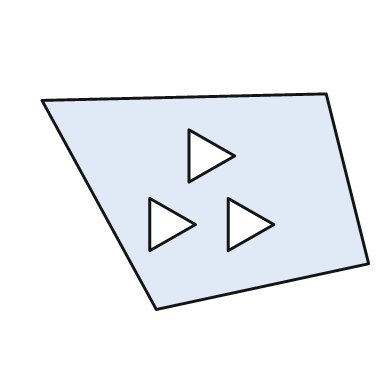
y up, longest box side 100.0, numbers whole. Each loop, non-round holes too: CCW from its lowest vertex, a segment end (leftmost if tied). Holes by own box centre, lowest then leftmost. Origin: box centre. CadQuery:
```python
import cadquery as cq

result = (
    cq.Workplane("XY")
    .moveTo(-15.0, -33.0)
    .lineTo(50.0, -19.0)
    .lineTo(37.0, 33.0)
    .lineTo(-50.0, 31.0)
    .close()
    .moveTo(-17.0, -15.0)
    .lineTo(-3.0, -7.0)
    .lineTo(-17.0, 1.0)
    .close()
    .moveTo(7.0, -15.0)
    .lineTo(21.0, -7.0)
    .lineTo(7.0, 1.0)
    .close()
    .moveTo(-5.0, 6.0)
    .lineTo(9.0, 14.0)
    .lineTo(-5.0, 22.0)
    .close()
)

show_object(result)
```